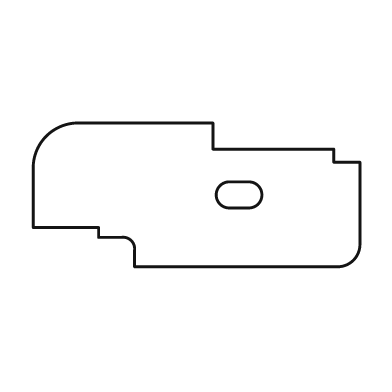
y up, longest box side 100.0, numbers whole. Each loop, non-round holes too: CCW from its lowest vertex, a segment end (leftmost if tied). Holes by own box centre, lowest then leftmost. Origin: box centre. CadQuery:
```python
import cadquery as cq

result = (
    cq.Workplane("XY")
    .moveTo(-19.0, -22.0)
    .lineTo(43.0, -22.0)
    .threePointArc((48.0, -20.0), (50.0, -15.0))
    .lineTo(50.0, 10.0)
    .lineTo(42.0, 10.0)
    .lineTo(42.0, 14.0)
    .lineTo(5.0, 14.0)
    .lineTo(5.0, 22.0)
    .lineTo(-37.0, 22.0)
    .threePointArc((-46.0, 18.0), (-50.0, 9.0))
    .lineTo(-50.0, -10.0)
    .lineTo(-30.0, -10.0)
    .lineTo(-30.0, -13.0)
    .lineTo(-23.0, -13.0)
    .threePointArc((-20.0, -14.0), (-19.0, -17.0))
    .close()
    .moveTo(10.0, -4.0)
    .lineTo(16.0, -4.0)
    .threePointArc((20.0, 0.0), (16.0, 4.0))
    .lineTo(10.0, 4.0)
    .threePointArc((6.0, 0.0), (10.0, -4.0))
    .close()
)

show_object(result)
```